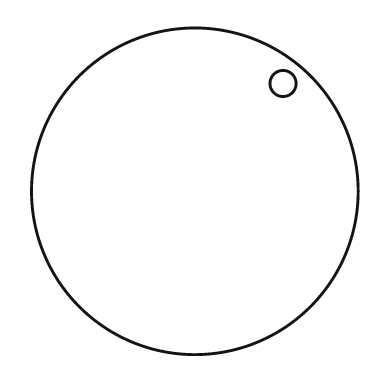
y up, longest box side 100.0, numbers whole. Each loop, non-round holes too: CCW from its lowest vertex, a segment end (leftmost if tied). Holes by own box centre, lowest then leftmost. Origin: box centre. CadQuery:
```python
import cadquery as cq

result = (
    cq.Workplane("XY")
    .moveTo(0.0, 0.0)
    .circle(50.0)
    .moveTo(27.0, 33.0)
    .circle(4.0)
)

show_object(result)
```